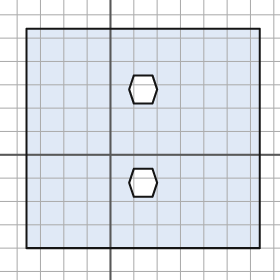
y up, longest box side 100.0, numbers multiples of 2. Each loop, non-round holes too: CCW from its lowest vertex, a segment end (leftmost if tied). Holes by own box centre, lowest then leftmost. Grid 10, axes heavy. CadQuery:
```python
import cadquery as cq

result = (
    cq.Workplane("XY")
    .moveTo(-36.0, -40.0)
    .lineTo(64.0, -40.0)
    .lineTo(64.0, 54.0)
    .lineTo(-36.0, 54.0)
    .close()
    .moveTo(10.0, -18.0)
    .lineTo(18.0, -18.0)
    .lineTo(20.0, -12.0)
    .lineTo(18.0, -6.0)
    .lineTo(10.0, -6.0)
    .lineTo(8.0, -12.0)
    .close()
    .moveTo(10.0, 22.0)
    .lineTo(18.0, 22.0)
    .lineTo(20.0, 28.0)
    .lineTo(18.0, 34.0)
    .lineTo(10.0, 34.0)
    .lineTo(8.0, 28.0)
    .close()
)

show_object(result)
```